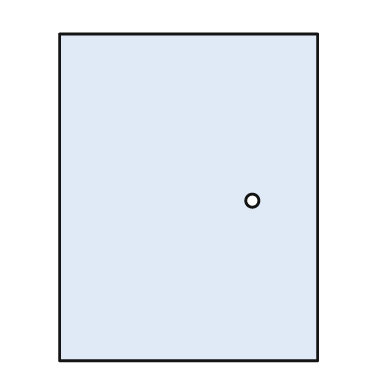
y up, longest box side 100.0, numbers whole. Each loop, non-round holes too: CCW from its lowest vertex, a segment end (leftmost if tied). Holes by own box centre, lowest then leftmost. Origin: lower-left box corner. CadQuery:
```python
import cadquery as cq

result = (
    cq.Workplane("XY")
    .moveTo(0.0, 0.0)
    .lineTo(79.0, 0.0)
    .lineTo(79.0, 100.0)
    .lineTo(0.0, 100.0)
    .close()
    .moveTo(59.0, 49.0)
    .circle(2.0)
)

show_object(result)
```